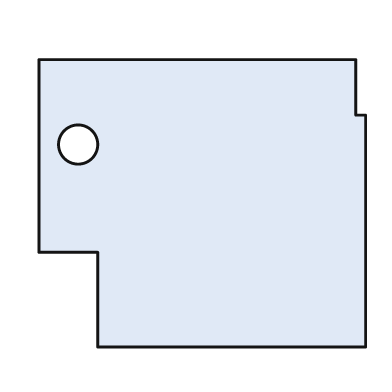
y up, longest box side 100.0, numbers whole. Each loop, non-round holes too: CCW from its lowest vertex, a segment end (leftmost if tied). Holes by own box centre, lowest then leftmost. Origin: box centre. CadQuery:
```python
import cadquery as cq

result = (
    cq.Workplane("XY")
    .moveTo(-32.0, -44.0)
    .lineTo(50.0, -44.0)
    .lineTo(50.0, 27.0)
    .lineTo(47.0, 27.0)
    .lineTo(47.0, 44.0)
    .lineTo(-50.0, 44.0)
    .lineTo(-50.0, -15.0)
    .lineTo(-32.0, -15.0)
    .close()
    .moveTo(-38.0, 18.0)
    .circle(6.0)
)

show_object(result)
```